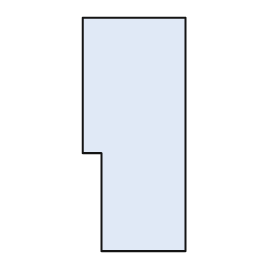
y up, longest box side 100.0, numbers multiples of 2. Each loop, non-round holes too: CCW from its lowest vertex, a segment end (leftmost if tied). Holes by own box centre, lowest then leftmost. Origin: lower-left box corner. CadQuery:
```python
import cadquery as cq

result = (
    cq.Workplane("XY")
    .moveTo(8.0, 0.0)
    .lineTo(44.0, 0.0)
    .lineTo(44.0, 100.0)
    .lineTo(0.0, 100.0)
    .lineTo(0.0, 42.0)
    .lineTo(8.0, 42.0)
    .close()
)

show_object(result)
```